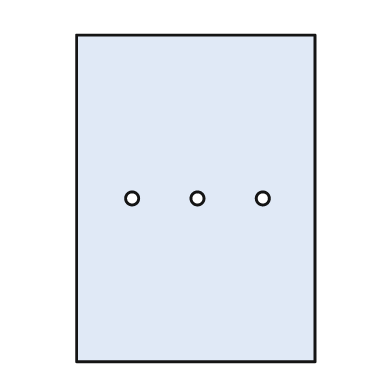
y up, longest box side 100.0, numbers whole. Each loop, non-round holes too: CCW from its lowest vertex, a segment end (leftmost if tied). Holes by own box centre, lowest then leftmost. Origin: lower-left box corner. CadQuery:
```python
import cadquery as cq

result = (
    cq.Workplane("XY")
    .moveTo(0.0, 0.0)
    .lineTo(73.0, 0.0)
    .lineTo(73.0, 100.0)
    .lineTo(0.0, 100.0)
    .close()
    .moveTo(17.0, 50.0)
    .circle(2.0)
    .moveTo(37.0, 50.0)
    .circle(2.0)
    .moveTo(57.0, 50.0)
    .circle(2.0)
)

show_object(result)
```